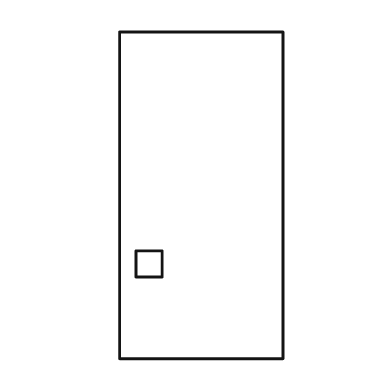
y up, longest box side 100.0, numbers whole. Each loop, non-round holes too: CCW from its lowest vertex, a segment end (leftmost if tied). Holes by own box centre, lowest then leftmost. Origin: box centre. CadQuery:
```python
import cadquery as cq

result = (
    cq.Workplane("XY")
    .moveTo(-25.0, -50.0)
    .lineTo(25.0, -50.0)
    .lineTo(25.0, 50.0)
    .lineTo(-25.0, 50.0)
    .close()
    .moveTo(-20.0, -25.0)
    .lineTo(-12.0, -25.0)
    .lineTo(-12.0, -17.0)
    .lineTo(-20.0, -17.0)
    .close()
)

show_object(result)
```